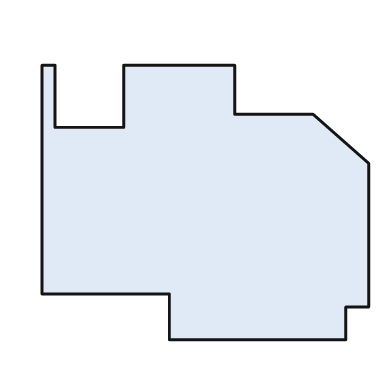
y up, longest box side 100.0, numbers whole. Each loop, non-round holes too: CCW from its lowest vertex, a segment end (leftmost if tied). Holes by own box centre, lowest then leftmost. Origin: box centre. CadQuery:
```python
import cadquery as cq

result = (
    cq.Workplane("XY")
    .moveTo(-11.0, -42.0)
    .lineTo(43.0, -42.0)
    .lineTo(43.0, -32.0)
    .lineTo(50.0, -32.0)
    .lineTo(50.0, 12.0)
    .lineTo(33.0, 27.0)
    .lineTo(9.0, 27.0)
    .lineTo(9.0, 42.0)
    .lineTo(-25.0, 42.0)
    .lineTo(-25.0, 23.0)
    .lineTo(-46.0, 23.0)
    .lineTo(-46.0, 42.0)
    .lineTo(-50.0, 42.0)
    .lineTo(-50.0, -28.0)
    .lineTo(-11.0, -28.0)
    .close()
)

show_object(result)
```